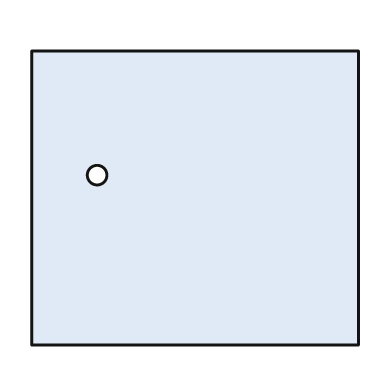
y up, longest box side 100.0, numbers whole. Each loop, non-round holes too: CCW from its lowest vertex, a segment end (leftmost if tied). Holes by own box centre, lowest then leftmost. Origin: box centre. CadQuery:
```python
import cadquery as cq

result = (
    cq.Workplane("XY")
    .moveTo(-50.0, -45.0)
    .lineTo(50.0, -45.0)
    .lineTo(50.0, 45.0)
    .lineTo(-50.0, 45.0)
    .close()
    .moveTo(-30.0, 7.0)
    .circle(3.0)
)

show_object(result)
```